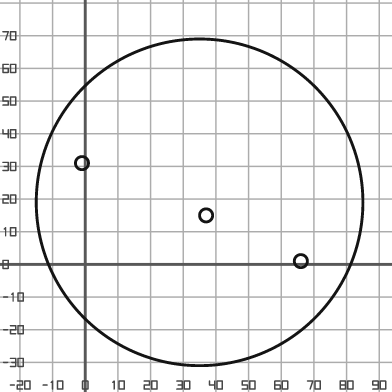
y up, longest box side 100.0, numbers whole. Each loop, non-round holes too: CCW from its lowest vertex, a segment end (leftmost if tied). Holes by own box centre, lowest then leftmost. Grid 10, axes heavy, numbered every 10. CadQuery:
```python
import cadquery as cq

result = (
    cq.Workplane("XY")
    .moveTo(35.0, 19.0)
    .circle(50.0)
    .moveTo(66.0, 1.0)
    .circle(2.0)
    .moveTo(37.0, 15.0)
    .circle(2.0)
    .moveTo(-1.0, 31.0)
    .circle(2.0)
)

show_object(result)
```